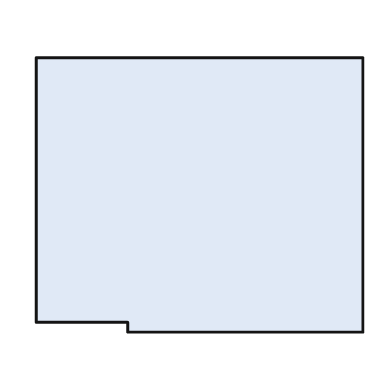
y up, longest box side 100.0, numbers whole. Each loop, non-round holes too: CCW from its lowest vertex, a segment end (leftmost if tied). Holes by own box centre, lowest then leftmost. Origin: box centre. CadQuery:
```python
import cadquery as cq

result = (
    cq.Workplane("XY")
    .moveTo(-22.0, -42.0)
    .lineTo(50.0, -42.0)
    .lineTo(50.0, 42.0)
    .lineTo(-50.0, 42.0)
    .lineTo(-50.0, -39.0)
    .lineTo(-22.0, -39.0)
    .close()
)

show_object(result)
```